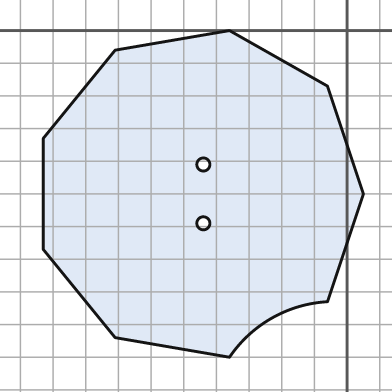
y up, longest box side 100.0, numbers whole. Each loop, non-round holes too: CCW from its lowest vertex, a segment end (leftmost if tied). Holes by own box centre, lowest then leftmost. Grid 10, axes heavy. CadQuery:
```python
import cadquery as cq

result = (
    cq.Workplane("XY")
    .moveTo(-36.0, -100.0)
    .threePointArc((-23.0, -88.0), (-6.0, -83.0))
    .lineTo(5.0, -50.0)
    .lineTo(-6.0, -17.0)
    .lineTo(-36.0, 0.0)
    .lineTo(-71.0, -6.0)
    .lineTo(-93.0, -33.0)
    .lineTo(-93.0, -67.0)
    .lineTo(-71.0, -94.0)
    .close()
    .moveTo(-44.0, -59.0)
    .circle(2.0)
    .moveTo(-44.0, -41.0)
    .circle(2.0)
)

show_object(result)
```